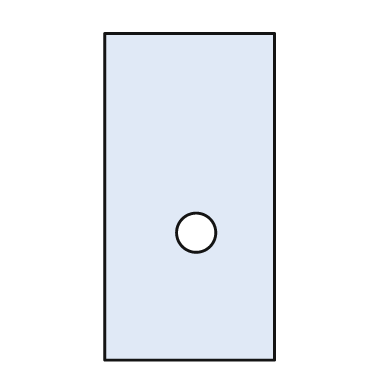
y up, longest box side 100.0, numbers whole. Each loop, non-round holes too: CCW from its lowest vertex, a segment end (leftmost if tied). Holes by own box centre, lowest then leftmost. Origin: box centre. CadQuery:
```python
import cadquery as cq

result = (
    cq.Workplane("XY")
    .moveTo(-26.0, -50.0)
    .lineTo(26.0, -50.0)
    .lineTo(26.0, 50.0)
    .lineTo(-26.0, 50.0)
    .close()
    .moveTo(2.0, -11.0)
    .circle(6.0)
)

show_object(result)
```